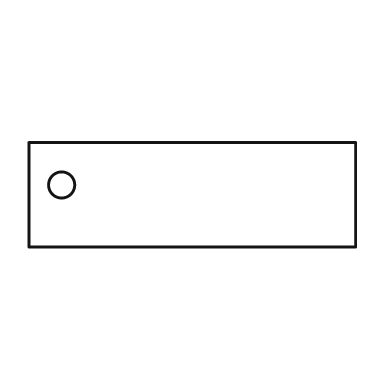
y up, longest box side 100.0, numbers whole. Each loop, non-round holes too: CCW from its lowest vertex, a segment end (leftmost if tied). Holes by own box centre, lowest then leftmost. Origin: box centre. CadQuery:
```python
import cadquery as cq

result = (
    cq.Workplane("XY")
    .moveTo(-50.0, -16.0)
    .lineTo(50.0, -16.0)
    .lineTo(50.0, 16.0)
    .lineTo(-50.0, 16.0)
    .close()
    .moveTo(-40.0, 3.0)
    .circle(4.0)
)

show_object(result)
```